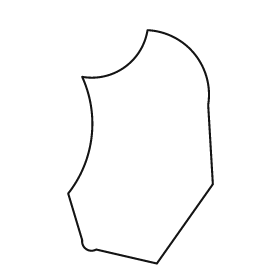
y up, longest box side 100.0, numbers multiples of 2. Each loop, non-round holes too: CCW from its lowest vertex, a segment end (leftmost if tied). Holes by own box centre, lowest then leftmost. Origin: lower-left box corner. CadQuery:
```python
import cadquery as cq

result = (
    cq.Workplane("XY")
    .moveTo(38.0, 0.0)
    .lineTo(62.0, 34.0)
    .lineTo(60.0, 68.0)
    .threePointArc((54.0, 90.0), (34.0, 100.0))
    .threePointArc((24.0, 84.0), (6.0, 80.0))
    .threePointArc((10.0, 54.0), (0.0, 30.0))
    .lineTo(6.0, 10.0)
    .threePointArc((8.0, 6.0), (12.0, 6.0))
    .close()
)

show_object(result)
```